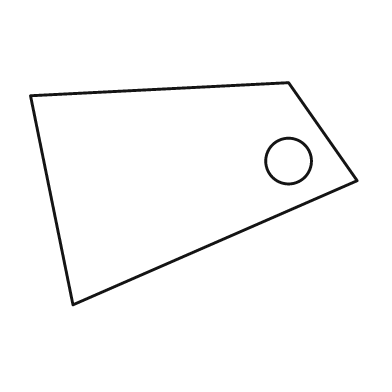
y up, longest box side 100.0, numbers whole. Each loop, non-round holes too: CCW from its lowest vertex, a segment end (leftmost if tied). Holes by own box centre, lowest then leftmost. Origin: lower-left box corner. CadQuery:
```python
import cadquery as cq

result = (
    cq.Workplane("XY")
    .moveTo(13.0, 0.0)
    .lineTo(100.0, 38.0)
    .lineTo(79.0, 68.0)
    .lineTo(0.0, 64.0)
    .close()
    .moveTo(79.0, 44.0)
    .circle(7.0)
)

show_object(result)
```